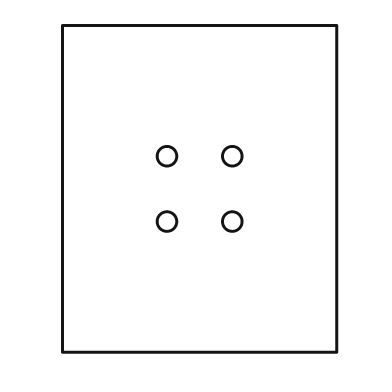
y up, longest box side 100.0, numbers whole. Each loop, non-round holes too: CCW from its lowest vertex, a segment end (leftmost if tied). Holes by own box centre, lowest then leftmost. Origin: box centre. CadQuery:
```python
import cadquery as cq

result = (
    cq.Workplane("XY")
    .moveTo(-42.0, -50.0)
    .lineTo(42.0, -50.0)
    .lineTo(42.0, 50.0)
    .lineTo(-42.0, 50.0)
    .close()
    .moveTo(-10.0, -10.0)
    .circle(3.0)
    .moveTo(10.0, -10.0)
    .circle(3.0)
    .moveTo(-10.0, 10.0)
    .circle(3.0)
    .moveTo(10.0, 10.0)
    .circle(3.0)
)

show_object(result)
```